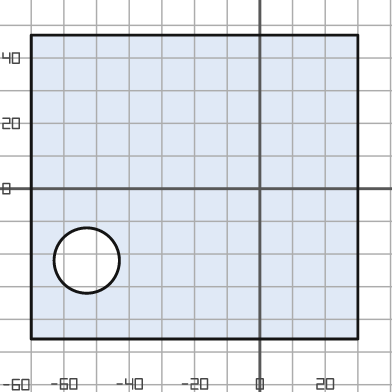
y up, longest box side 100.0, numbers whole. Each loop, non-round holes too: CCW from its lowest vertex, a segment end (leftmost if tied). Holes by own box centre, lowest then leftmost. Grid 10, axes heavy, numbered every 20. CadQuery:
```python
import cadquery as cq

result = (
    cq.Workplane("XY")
    .moveTo(-70.0, -46.0)
    .lineTo(30.0, -46.0)
    .lineTo(30.0, 47.0)
    .lineTo(-70.0, 47.0)
    .close()
    .moveTo(-53.0, -22.0)
    .circle(10.0)
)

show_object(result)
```